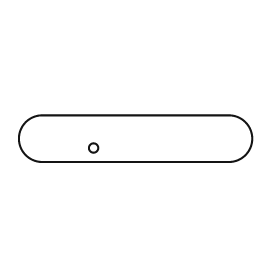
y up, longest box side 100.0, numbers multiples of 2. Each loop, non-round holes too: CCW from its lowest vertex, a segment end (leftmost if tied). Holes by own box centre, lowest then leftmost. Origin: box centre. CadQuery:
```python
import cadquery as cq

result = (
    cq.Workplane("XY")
    .moveTo(-40.0, -10.0)
    .lineTo(40.0, -10.0)
    .threePointArc((50.0, 0.0), (40.0, 10.0))
    .lineTo(-40.0, 10.0)
    .threePointArc((-50.0, 0.0), (-40.0, -10.0))
    .close()
    .moveTo(-18.0, -4.0)
    .circle(2.0)
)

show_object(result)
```